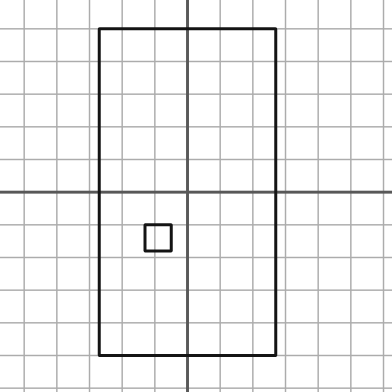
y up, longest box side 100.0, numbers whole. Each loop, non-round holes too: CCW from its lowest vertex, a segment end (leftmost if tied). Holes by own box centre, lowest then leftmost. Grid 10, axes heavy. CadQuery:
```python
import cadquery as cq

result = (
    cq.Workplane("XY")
    .moveTo(-27.0, -50.0)
    .lineTo(27.0, -50.0)
    .lineTo(27.0, 50.0)
    .lineTo(-27.0, 50.0)
    .close()
    .moveTo(-13.0, -18.0)
    .lineTo(-5.0, -18.0)
    .lineTo(-5.0, -10.0)
    .lineTo(-13.0, -10.0)
    .close()
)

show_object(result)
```